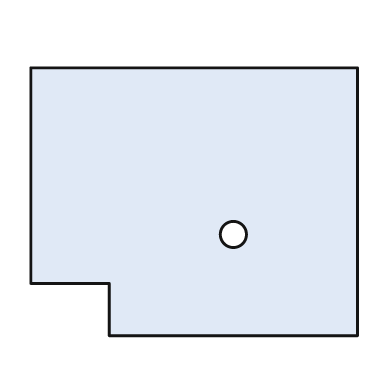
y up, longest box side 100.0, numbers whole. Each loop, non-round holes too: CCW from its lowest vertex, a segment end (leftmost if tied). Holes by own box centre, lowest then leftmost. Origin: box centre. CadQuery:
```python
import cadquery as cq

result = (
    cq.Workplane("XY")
    .moveTo(-26.0, -41.0)
    .lineTo(50.0, -41.0)
    .lineTo(50.0, 41.0)
    .lineTo(-50.0, 41.0)
    .lineTo(-50.0, -25.0)
    .lineTo(-26.0, -25.0)
    .close()
    .moveTo(12.0, -10.0)
    .circle(4.0)
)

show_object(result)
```